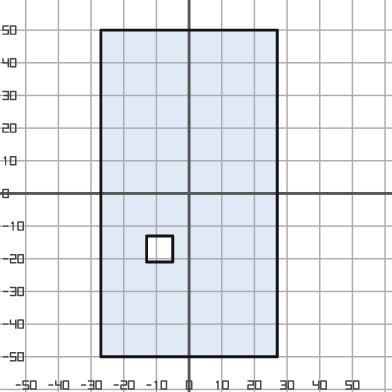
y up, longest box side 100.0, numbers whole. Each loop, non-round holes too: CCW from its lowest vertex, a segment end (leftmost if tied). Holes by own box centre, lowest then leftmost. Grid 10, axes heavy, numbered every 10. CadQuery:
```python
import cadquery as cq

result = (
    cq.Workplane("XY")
    .moveTo(-27.0, -50.0)
    .lineTo(27.0, -50.0)
    .lineTo(27.0, 50.0)
    .lineTo(-27.0, 50.0)
    .close()
    .moveTo(-13.0, -21.0)
    .lineTo(-5.0, -21.0)
    .lineTo(-5.0, -13.0)
    .lineTo(-13.0, -13.0)
    .close()
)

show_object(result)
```